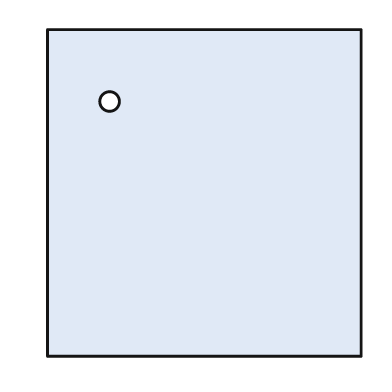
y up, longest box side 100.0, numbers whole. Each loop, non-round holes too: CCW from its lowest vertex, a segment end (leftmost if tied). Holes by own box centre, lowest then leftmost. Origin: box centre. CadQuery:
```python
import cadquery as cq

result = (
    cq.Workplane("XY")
    .moveTo(-48.0, -50.0)
    .lineTo(48.0, -50.0)
    .lineTo(48.0, 50.0)
    .lineTo(-48.0, 50.0)
    .close()
    .moveTo(-29.0, 28.0)
    .circle(3.0)
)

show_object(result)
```